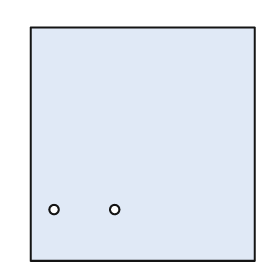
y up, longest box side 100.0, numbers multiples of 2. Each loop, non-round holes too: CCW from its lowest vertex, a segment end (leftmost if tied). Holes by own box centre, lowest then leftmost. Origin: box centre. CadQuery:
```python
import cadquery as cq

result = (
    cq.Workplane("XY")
    .moveTo(-48.0, -50.0)
    .lineTo(48.0, -50.0)
    .lineTo(48.0, 50.0)
    .lineTo(-48.0, 50.0)
    .close()
    .moveTo(-38.0, -28.0)
    .circle(2.0)
    .moveTo(-12.0, -28.0)
    .circle(2.0)
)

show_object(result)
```